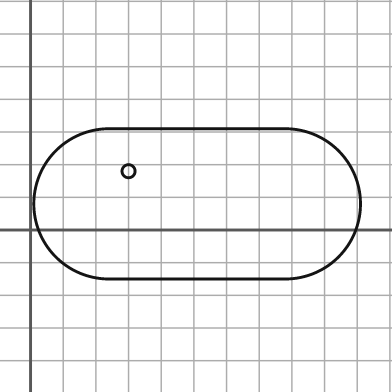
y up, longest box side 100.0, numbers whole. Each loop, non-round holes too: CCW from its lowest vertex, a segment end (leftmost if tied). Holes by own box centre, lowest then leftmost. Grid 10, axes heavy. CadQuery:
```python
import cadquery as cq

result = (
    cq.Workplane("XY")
    .moveTo(24.0, -15.0)
    .lineTo(78.0, -15.0)
    .threePointArc((101.0, 8.0), (78.0, 31.0))
    .lineTo(24.0, 31.0)
    .threePointArc((1.0, 8.0), (24.0, -15.0))
    .close()
    .moveTo(30.0, 18.0)
    .circle(2.0)
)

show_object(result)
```